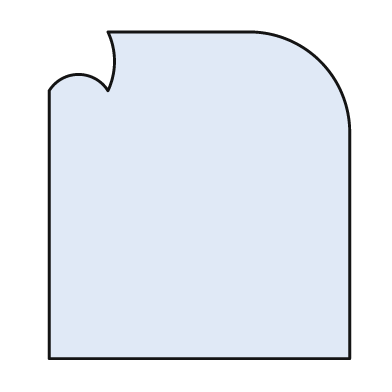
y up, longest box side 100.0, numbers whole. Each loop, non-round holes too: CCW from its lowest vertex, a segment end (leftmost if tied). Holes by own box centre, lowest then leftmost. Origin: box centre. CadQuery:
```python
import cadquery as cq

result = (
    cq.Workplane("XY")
    .moveTo(-46.0, -50.0)
    .lineTo(46.0, -50.0)
    .lineTo(46.0, 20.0)
    .threePointArc((37.0, 41.0), (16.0, 50.0))
    .lineTo(-28.0, 50.0)
    .threePointArc((-26.0, 41.0), (-28.0, 32.0))
    .threePointArc((-37.0, 37.0), (-46.0, 32.0))
    .close()
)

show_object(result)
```